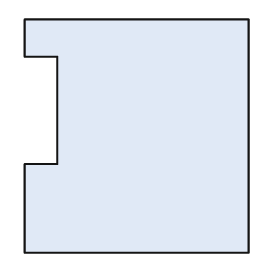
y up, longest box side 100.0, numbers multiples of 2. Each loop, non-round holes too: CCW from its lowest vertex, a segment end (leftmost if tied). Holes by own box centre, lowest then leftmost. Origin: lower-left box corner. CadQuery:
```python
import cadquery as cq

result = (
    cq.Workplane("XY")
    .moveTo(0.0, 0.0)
    .lineTo(96.0, 0.0)
    .lineTo(96.0, 100.0)
    .lineTo(0.0, 100.0)
    .lineTo(0.0, 84.0)
    .lineTo(14.0, 84.0)
    .lineTo(14.0, 38.0)
    .lineTo(0.0, 38.0)
    .close()
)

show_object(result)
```